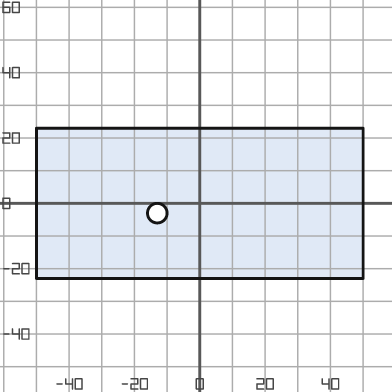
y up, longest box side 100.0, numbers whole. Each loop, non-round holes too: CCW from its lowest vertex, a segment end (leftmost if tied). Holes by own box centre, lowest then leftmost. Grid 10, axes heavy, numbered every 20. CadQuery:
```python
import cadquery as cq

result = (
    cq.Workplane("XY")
    .moveTo(-50.0, -23.0)
    .lineTo(50.0, -23.0)
    .lineTo(50.0, 23.0)
    .lineTo(-50.0, 23.0)
    .close()
    .moveTo(-13.0, -3.0)
    .circle(3.0)
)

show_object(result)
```